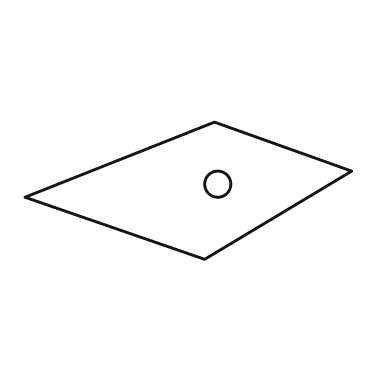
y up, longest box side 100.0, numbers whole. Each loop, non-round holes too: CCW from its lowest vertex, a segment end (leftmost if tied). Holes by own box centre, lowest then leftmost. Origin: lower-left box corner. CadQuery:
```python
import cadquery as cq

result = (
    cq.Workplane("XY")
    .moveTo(55.0, 0.0)
    .lineTo(100.0, 27.0)
    .lineTo(58.0, 42.0)
    .lineTo(0.0, 19.0)
    .close()
    .moveTo(59.0, 23.0)
    .circle(4.0)
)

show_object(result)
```